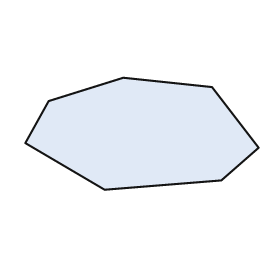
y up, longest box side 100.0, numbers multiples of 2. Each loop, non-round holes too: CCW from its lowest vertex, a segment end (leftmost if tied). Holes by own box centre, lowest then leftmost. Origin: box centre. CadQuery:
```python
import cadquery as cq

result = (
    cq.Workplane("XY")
    .moveTo(-16.0, -24.0)
    .lineTo(34.0, -20.0)
    .lineTo(50.0, -6.0)
    .lineTo(30.0, 20.0)
    .lineTo(-8.0, 24.0)
    .lineTo(-40.0, 14.0)
    .lineTo(-50.0, -4.0)
    .close()
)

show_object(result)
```